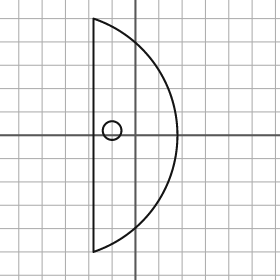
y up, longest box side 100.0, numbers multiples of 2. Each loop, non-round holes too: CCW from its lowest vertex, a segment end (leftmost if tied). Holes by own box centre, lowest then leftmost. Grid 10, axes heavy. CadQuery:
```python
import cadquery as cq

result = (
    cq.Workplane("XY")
    .moveTo(-18.0, -50.0)
    .threePointArc((18.0, 0.0), (-18.0, 50.0))
    .close()
    .moveTo(-10.0, 2.0)
    .circle(4.0)
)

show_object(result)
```